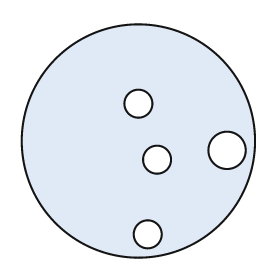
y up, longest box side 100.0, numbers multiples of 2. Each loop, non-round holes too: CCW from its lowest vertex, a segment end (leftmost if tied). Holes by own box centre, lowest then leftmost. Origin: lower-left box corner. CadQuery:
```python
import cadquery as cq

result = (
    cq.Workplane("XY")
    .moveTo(50.0, 50.0)
    .circle(50.0)
    .moveTo(54.0, 10.0)
    .circle(6.0)
    .moveTo(58.0, 42.0)
    .circle(6.0)
    .moveTo(88.0, 46.0)
    .circle(8.0)
    .moveTo(50.0, 66.0)
    .circle(6.0)
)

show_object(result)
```